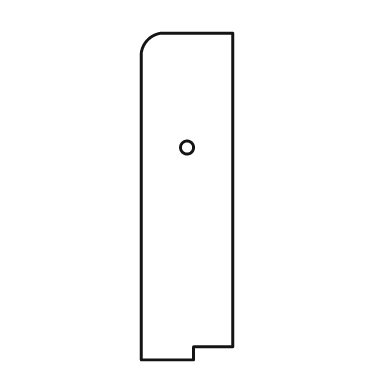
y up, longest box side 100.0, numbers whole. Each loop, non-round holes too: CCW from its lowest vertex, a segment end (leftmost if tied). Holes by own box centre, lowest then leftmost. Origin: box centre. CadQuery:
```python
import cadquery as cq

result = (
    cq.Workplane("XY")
    .moveTo(-14.0, -50.0)
    .lineTo(2.0, -50.0)
    .lineTo(2.0, -46.0)
    .lineTo(14.0, -46.0)
    .lineTo(14.0, 50.0)
    .lineTo(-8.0, 50.0)
    .threePointArc((-12.0, 48.0), (-14.0, 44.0))
    .close()
    .moveTo(0.0, 15.0)
    .circle(2.0)
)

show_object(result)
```